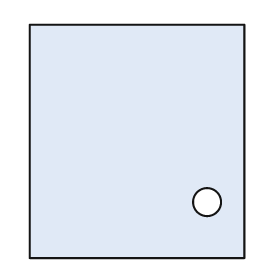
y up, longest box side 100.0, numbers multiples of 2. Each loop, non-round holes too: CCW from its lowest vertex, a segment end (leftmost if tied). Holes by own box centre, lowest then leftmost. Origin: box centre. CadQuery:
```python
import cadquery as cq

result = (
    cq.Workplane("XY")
    .moveTo(-46.0, -50.0)
    .lineTo(46.0, -50.0)
    .lineTo(46.0, 50.0)
    .lineTo(-46.0, 50.0)
    .close()
    .moveTo(30.0, -26.0)
    .circle(6.0)
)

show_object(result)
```